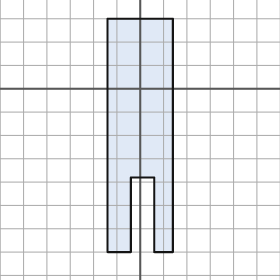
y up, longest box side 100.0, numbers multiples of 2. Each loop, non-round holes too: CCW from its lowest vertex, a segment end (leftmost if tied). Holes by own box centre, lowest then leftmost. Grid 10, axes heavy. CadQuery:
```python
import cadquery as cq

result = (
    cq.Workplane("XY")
    .moveTo(-14.0, -70.0)
    .lineTo(-4.0, -70.0)
    .lineTo(-4.0, -38.0)
    .lineTo(6.0, -38.0)
    .lineTo(6.0, -70.0)
    .lineTo(14.0, -70.0)
    .lineTo(14.0, 30.0)
    .lineTo(-14.0, 30.0)
    .close()
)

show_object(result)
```